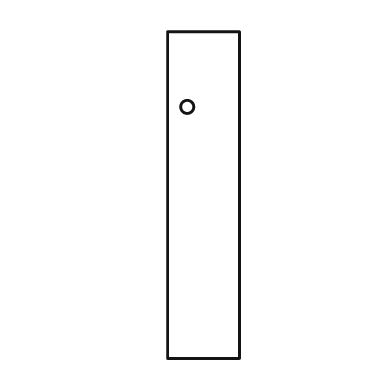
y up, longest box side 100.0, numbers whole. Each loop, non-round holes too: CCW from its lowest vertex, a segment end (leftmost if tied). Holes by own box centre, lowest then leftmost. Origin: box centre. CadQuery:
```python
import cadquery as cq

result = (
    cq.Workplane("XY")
    .moveTo(-11.0, -50.0)
    .lineTo(11.0, -50.0)
    .lineTo(11.0, 50.0)
    .lineTo(-11.0, 50.0)
    .close()
    .moveTo(-5.0, 27.0)
    .circle(2.0)
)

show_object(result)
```